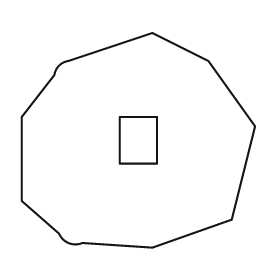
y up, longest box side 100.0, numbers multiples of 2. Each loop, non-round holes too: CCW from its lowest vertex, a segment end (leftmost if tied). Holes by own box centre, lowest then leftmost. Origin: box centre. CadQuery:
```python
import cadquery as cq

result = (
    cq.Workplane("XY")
    .moveTo(6.0, -46.0)
    .lineTo(40.0, -34.0)
    .lineTo(50.0, 6.0)
    .lineTo(30.0, 34.0)
    .lineTo(6.0, 46.0)
    .lineTo(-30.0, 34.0)
    .threePointArc((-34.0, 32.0), (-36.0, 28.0))
    .lineTo(-50.0, 10.0)
    .lineTo(-50.0, -26.0)
    .lineTo(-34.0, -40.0)
    .threePointArc((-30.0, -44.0), (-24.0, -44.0))
    .close()
    .moveTo(-8.0, -10.0)
    .lineTo(8.0, -10.0)
    .lineTo(8.0, 10.0)
    .lineTo(-8.0, 10.0)
    .close()
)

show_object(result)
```